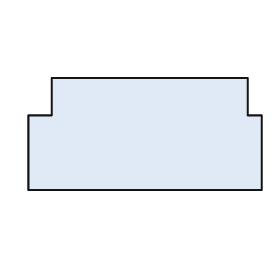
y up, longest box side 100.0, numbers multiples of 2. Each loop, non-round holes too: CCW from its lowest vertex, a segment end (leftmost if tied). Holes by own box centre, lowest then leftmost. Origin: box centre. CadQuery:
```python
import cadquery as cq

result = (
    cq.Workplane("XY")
    .moveTo(-50.0, -24.0)
    .lineTo(50.0, -24.0)
    .lineTo(50.0, 8.0)
    .lineTo(44.0, 8.0)
    .lineTo(44.0, 24.0)
    .lineTo(-40.0, 24.0)
    .lineTo(-40.0, 8.0)
    .lineTo(-50.0, 8.0)
    .close()
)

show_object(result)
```